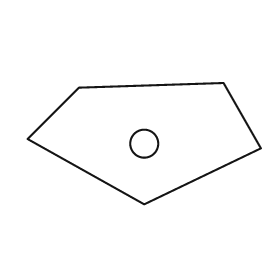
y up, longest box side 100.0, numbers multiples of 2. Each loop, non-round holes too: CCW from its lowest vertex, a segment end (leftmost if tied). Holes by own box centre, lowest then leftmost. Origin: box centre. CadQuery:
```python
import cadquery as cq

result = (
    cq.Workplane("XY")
    .moveTo(0.0, -26.0)
    .lineTo(50.0, -2.0)
    .lineTo(34.0, 26.0)
    .lineTo(-28.0, 24.0)
    .lineTo(-50.0, 2.0)
    .close()
    .moveTo(0.0, 0.0)
    .circle(6.0)
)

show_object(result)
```